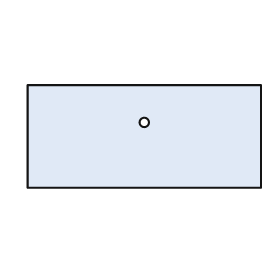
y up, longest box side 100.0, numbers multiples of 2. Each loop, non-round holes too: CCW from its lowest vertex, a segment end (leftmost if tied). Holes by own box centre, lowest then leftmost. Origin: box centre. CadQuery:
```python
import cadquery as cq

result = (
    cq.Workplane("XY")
    .moveTo(-50.0, -22.0)
    .lineTo(50.0, -22.0)
    .lineTo(50.0, 22.0)
    .lineTo(-50.0, 22.0)
    .close()
    .moveTo(0.0, 6.0)
    .circle(2.0)
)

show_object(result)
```